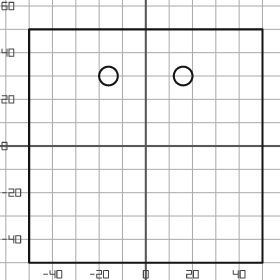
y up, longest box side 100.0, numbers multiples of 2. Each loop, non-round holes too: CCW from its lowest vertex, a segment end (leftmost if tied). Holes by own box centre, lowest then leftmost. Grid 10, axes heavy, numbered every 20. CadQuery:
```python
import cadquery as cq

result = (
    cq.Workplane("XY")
    .moveTo(-50.0, -50.0)
    .lineTo(50.0, -50.0)
    .lineTo(50.0, 50.0)
    .lineTo(-50.0, 50.0)
    .close()
    .moveTo(-16.0, 30.0)
    .circle(4.0)
    .moveTo(16.0, 30.0)
    .circle(4.0)
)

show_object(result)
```